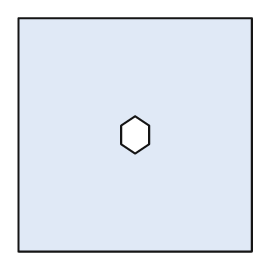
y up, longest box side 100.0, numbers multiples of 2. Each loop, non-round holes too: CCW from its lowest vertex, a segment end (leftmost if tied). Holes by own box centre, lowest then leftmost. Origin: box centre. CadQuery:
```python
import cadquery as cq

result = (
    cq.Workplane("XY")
    .moveTo(-50.0, -50.0)
    .lineTo(50.0, -50.0)
    .lineTo(50.0, 50.0)
    .lineTo(-50.0, 50.0)
    .close()
    .moveTo(0.0, -8.0)
    .lineTo(6.0, -4.0)
    .lineTo(6.0, 4.0)
    .lineTo(0.0, 8.0)
    .lineTo(-6.0, 4.0)
    .lineTo(-6.0, -4.0)
    .close()
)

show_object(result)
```